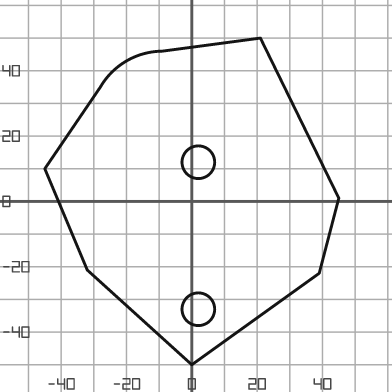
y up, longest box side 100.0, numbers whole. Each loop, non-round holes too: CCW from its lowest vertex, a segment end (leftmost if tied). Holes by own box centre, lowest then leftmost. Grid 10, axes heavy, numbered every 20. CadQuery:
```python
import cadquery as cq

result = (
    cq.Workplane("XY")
    .moveTo(0.0, -50.0)
    .lineTo(39.0, -22.0)
    .lineTo(45.0, 1.0)
    .lineTo(21.0, 50.0)
    .lineTo(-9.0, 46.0)
    .threePointArc((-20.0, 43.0), (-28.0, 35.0))
    .lineTo(-45.0, 10.0)
    .lineTo(-32.0, -21.0)
    .close()
    .moveTo(2.0, -33.0)
    .circle(5.0)
    .moveTo(2.0, 12.0)
    .circle(5.0)
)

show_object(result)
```